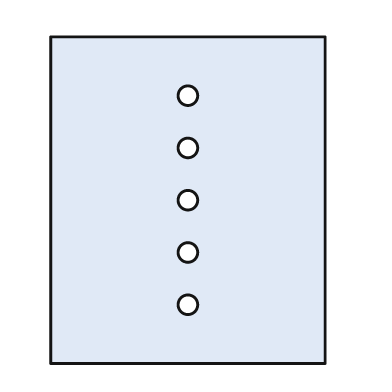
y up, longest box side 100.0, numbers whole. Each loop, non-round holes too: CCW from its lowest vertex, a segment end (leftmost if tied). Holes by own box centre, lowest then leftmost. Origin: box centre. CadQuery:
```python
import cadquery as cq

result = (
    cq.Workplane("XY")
    .moveTo(-42.0, -50.0)
    .lineTo(42.0, -50.0)
    .lineTo(42.0, 50.0)
    .lineTo(-42.0, 50.0)
    .close()
    .moveTo(0.0, -32.0)
    .circle(3.0)
    .moveTo(0.0, -16.0)
    .circle(3.0)
    .moveTo(0.0, 0.0)
    .circle(3.0)
    .moveTo(0.0, 16.0)
    .circle(3.0)
    .moveTo(0.0, 32.0)
    .circle(3.0)
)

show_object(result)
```